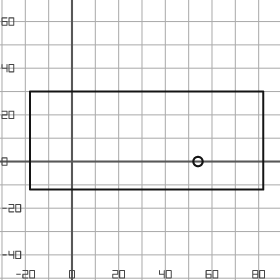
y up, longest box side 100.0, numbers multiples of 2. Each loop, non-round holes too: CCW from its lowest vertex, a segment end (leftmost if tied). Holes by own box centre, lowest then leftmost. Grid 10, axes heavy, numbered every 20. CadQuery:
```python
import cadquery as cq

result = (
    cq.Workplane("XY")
    .moveTo(-18.0, -12.0)
    .lineTo(82.0, -12.0)
    .lineTo(82.0, 30.0)
    .lineTo(-18.0, 30.0)
    .close()
    .moveTo(54.0, 0.0)
    .circle(2.0)
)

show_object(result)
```